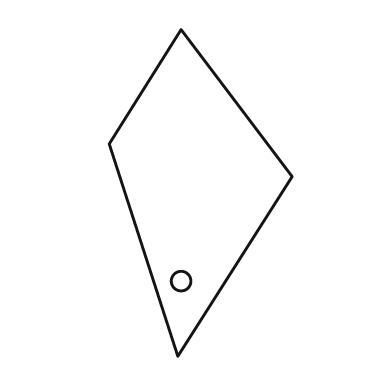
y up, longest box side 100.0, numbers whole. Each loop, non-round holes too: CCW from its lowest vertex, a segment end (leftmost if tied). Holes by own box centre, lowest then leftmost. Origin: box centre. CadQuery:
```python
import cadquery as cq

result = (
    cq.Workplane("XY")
    .moveTo(-7.0, -50.0)
    .lineTo(28.0, 5.0)
    .lineTo(-6.0, 50.0)
    .lineTo(-28.0, 15.0)
    .close()
    .moveTo(-6.0, -27.0)
    .circle(3.0)
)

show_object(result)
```